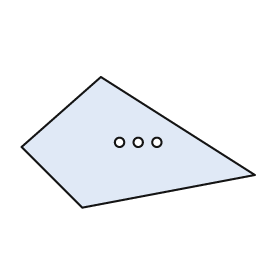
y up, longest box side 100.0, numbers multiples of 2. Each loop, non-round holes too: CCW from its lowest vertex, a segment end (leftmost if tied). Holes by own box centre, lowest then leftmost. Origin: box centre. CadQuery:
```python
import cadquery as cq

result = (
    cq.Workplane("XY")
    .moveTo(-24.0, -28.0)
    .lineTo(50.0, -14.0)
    .lineTo(-16.0, 28.0)
    .lineTo(-50.0, -2.0)
    .close()
    .moveTo(-8.0, 0.0)
    .circle(2.0)
    .moveTo(0.0, 0.0)
    .circle(2.0)
    .moveTo(8.0, 0.0)
    .circle(2.0)
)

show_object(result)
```